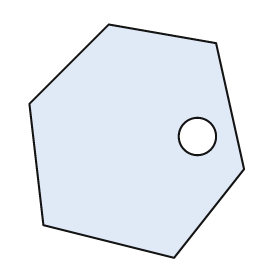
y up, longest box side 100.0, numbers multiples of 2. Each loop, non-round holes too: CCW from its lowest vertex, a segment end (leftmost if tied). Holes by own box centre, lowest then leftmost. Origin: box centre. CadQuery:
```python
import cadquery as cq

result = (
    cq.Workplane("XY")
    .moveTo(16.0, -50.0)
    .lineTo(46.0, -12.0)
    .lineTo(34.0, 42.0)
    .lineTo(-12.0, 50.0)
    .lineTo(-46.0, 16.0)
    .lineTo(-40.0, -36.0)
    .close()
    .moveTo(26.0, 2.0)
    .circle(8.0)
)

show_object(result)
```